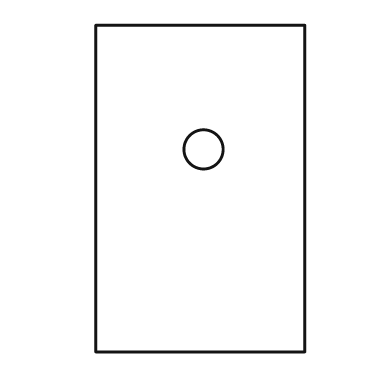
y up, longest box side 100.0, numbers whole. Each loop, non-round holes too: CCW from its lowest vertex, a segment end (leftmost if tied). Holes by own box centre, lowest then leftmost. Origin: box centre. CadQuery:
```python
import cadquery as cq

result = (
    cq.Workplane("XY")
    .moveTo(-32.0, -50.0)
    .lineTo(32.0, -50.0)
    .lineTo(32.0, 50.0)
    .lineTo(-32.0, 50.0)
    .close()
    .moveTo(1.0, 12.0)
    .circle(6.0)
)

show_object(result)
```